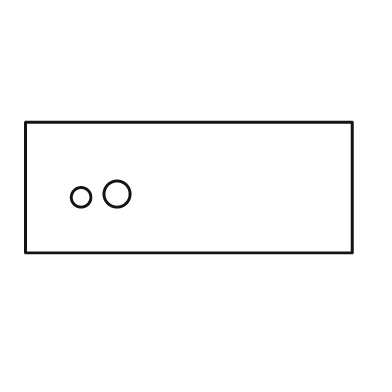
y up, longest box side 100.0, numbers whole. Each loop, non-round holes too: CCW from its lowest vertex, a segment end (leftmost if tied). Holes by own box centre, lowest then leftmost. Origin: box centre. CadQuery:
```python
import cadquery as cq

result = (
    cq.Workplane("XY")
    .moveTo(-50.0, -20.0)
    .lineTo(50.0, -20.0)
    .lineTo(50.0, 20.0)
    .lineTo(-50.0, 20.0)
    .close()
    .moveTo(-33.0, -3.0)
    .circle(3.0)
    .moveTo(-22.0, -2.0)
    .circle(4.0)
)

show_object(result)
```